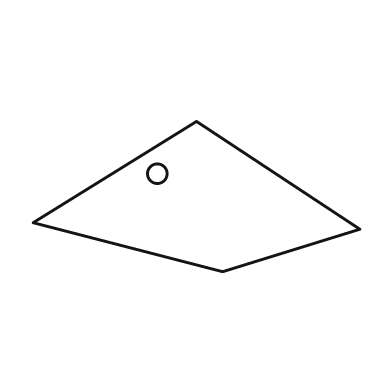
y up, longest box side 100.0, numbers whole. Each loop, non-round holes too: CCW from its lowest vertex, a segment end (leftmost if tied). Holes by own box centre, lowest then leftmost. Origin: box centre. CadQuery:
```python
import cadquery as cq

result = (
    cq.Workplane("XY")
    .moveTo(8.0, -23.0)
    .lineTo(50.0, -10.0)
    .lineTo(0.0, 23.0)
    .lineTo(-50.0, -8.0)
    .close()
    .moveTo(-12.0, 7.0)
    .circle(3.0)
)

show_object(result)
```